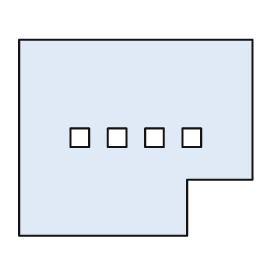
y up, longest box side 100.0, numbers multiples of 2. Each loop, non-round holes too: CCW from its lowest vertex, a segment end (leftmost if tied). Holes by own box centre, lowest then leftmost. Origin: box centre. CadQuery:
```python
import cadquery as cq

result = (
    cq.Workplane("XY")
    .moveTo(-50.0, -42.0)
    .lineTo(22.0, -42.0)
    .lineTo(22.0, -18.0)
    .lineTo(50.0, -18.0)
    .lineTo(50.0, 42.0)
    .lineTo(-50.0, 42.0)
    .close()
    .moveTo(-28.0, -4.0)
    .lineTo(-20.0, -4.0)
    .lineTo(-20.0, 4.0)
    .lineTo(-28.0, 4.0)
    .close()
    .moveTo(-12.0, -4.0)
    .lineTo(-4.0, -4.0)
    .lineTo(-4.0, 4.0)
    .lineTo(-12.0, 4.0)
    .close()
    .moveTo(4.0, -4.0)
    .lineTo(12.0, -4.0)
    .lineTo(12.0, 4.0)
    .lineTo(4.0, 4.0)
    .close()
    .moveTo(20.0, -4.0)
    .lineTo(28.0, -4.0)
    .lineTo(28.0, 4.0)
    .lineTo(20.0, 4.0)
    .close()
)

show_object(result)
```